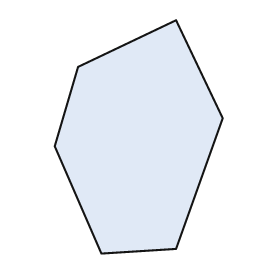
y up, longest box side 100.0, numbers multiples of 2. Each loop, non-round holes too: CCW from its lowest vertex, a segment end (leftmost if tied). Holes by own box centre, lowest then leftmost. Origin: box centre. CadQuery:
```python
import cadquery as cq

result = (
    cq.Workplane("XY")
    .moveTo(-16.0, -50.0)
    .lineTo(16.0, -48.0)
    .lineTo(36.0, 8.0)
    .lineTo(16.0, 50.0)
    .lineTo(-26.0, 30.0)
    .lineTo(-36.0, -4.0)
    .close()
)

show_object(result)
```